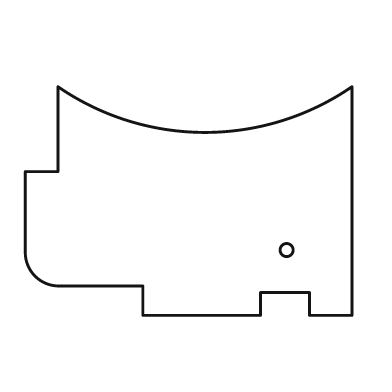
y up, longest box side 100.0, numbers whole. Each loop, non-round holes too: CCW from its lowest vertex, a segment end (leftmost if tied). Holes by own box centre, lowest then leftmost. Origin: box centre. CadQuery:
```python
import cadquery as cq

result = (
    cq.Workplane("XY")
    .moveTo(-14.0, -35.0)
    .lineTo(22.0, -35.0)
    .lineTo(22.0, -28.0)
    .lineTo(37.0, -28.0)
    .lineTo(37.0, -35.0)
    .lineTo(50.0, -35.0)
    .lineTo(50.0, 35.0)
    .threePointArc((5.0, 21.0), (-40.0, 35.0))
    .lineTo(-40.0, 9.0)
    .lineTo(-50.0, 9.0)
    .lineTo(-50.0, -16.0)
    .threePointArc((-47.0, -23.0), (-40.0, -26.0))
    .lineTo(-14.0, -26.0)
    .close()
    .moveTo(30.0, -15.0)
    .circle(2.0)
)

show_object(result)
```